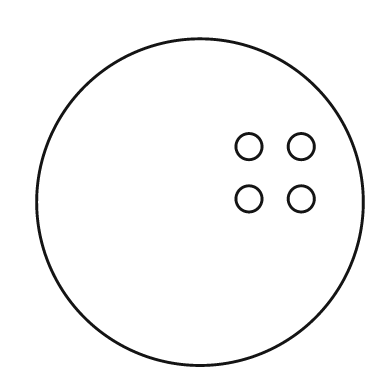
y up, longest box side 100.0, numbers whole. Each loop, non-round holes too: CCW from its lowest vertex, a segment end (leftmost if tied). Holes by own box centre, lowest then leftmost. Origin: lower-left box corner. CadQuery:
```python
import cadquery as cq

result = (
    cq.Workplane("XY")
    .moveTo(50.0, 50.0)
    .circle(50.0)
    .moveTo(65.0, 51.0)
    .circle(4.0)
    .moveTo(81.0, 51.0)
    .circle(4.0)
    .moveTo(65.0, 67.0)
    .circle(4.0)
    .moveTo(81.0, 67.0)
    .circle(4.0)
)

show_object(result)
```